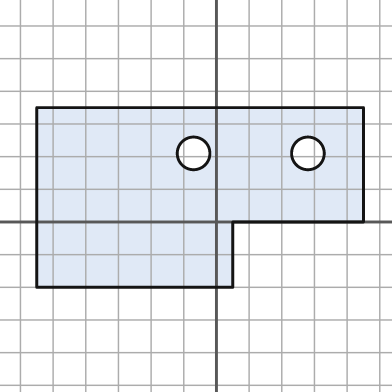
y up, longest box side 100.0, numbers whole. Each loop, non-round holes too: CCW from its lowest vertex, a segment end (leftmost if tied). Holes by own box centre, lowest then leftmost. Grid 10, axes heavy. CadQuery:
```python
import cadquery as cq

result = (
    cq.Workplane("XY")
    .moveTo(-55.0, -20.0)
    .lineTo(5.0, -20.0)
    .lineTo(5.0, 0.0)
    .lineTo(45.0, 0.0)
    .lineTo(45.0, 35.0)
    .lineTo(-55.0, 35.0)
    .close()
    .moveTo(-7.0, 21.0)
    .circle(5.0)
    .moveTo(28.0, 21.0)
    .circle(5.0)
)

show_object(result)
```